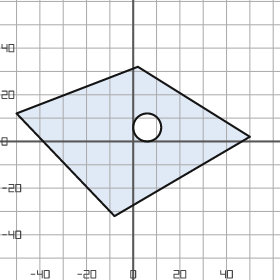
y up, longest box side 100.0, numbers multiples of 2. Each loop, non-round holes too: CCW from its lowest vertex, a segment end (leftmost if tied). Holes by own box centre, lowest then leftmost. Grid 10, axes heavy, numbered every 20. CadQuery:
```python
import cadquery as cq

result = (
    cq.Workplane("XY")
    .moveTo(-8.0, -32.0)
    .lineTo(50.0, 2.0)
    .lineTo(2.0, 32.0)
    .lineTo(-50.0, 12.0)
    .close()
    .moveTo(6.0, 6.0)
    .circle(6.0)
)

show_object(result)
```